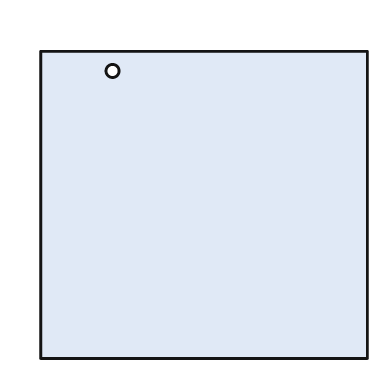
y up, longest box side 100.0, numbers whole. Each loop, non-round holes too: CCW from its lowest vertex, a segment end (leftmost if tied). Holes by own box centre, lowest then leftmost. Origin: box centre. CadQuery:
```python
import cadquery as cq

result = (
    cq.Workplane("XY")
    .moveTo(-50.0, -47.0)
    .lineTo(50.0, -47.0)
    .lineTo(50.0, 47.0)
    .lineTo(-50.0, 47.0)
    .close()
    .moveTo(-28.0, 41.0)
    .circle(2.0)
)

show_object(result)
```